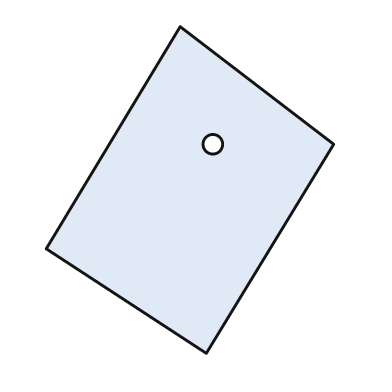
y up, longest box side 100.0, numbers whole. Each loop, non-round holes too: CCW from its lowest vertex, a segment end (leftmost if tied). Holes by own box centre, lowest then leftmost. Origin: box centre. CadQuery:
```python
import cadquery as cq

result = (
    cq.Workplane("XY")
    .moveTo(5.0, -50.0)
    .lineTo(44.0, 14.0)
    .lineTo(-3.0, 50.0)
    .lineTo(-44.0, -18.0)
    .close()
    .moveTo(7.0, 14.0)
    .circle(3.0)
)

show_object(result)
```